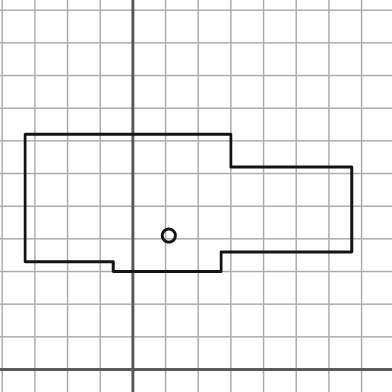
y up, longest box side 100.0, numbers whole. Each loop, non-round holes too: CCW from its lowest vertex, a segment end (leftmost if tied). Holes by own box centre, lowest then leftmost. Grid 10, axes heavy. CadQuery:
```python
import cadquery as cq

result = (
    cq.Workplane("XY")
    .moveTo(-6.0, 30.0)
    .lineTo(27.0, 30.0)
    .lineTo(27.0, 36.0)
    .lineTo(67.0, 36.0)
    .lineTo(67.0, 62.0)
    .lineTo(30.0, 62.0)
    .lineTo(30.0, 72.0)
    .lineTo(-33.0, 72.0)
    .lineTo(-33.0, 33.0)
    .lineTo(-6.0, 33.0)
    .close()
    .moveTo(11.0, 41.0)
    .circle(2.0)
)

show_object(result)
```